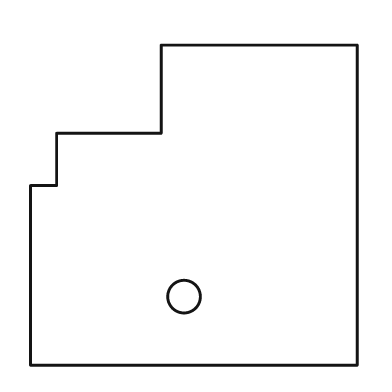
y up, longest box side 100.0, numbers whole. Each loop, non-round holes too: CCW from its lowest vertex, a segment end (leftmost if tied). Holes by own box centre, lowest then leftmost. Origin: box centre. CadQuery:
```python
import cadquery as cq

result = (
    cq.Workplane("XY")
    .moveTo(-50.0, -49.0)
    .lineTo(50.0, -49.0)
    .lineTo(50.0, 49.0)
    .lineTo(-10.0, 49.0)
    .lineTo(-10.0, 22.0)
    .lineTo(-42.0, 22.0)
    .lineTo(-42.0, 6.0)
    .lineTo(-50.0, 6.0)
    .close()
    .moveTo(-3.0, -28.0)
    .circle(5.0)
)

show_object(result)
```